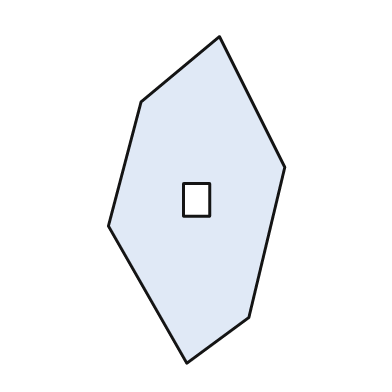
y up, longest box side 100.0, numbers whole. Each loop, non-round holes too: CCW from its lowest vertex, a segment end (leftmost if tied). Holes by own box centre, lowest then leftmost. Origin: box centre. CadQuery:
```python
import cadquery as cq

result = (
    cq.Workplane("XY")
    .moveTo(-3.0, -50.0)
    .lineTo(16.0, -36.0)
    .lineTo(27.0, 10.0)
    .lineTo(7.0, 50.0)
    .lineTo(-17.0, 30.0)
    .lineTo(-27.0, -8.0)
    .close()
    .moveTo(-4.0, -5.0)
    .lineTo(4.0, -5.0)
    .lineTo(4.0, 5.0)
    .lineTo(-4.0, 5.0)
    .close()
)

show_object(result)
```